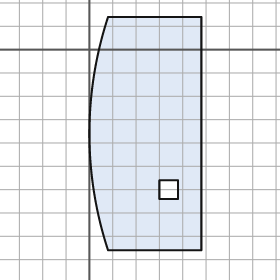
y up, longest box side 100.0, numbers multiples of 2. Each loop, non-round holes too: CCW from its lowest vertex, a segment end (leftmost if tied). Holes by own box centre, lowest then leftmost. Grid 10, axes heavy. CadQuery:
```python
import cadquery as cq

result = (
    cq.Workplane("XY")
    .moveTo(8.0, -86.0)
    .lineTo(48.0, -86.0)
    .lineTo(48.0, 14.0)
    .lineTo(8.0, 14.0)
    .threePointArc((0.0, -36.0), (8.0, -86.0))
    .close()
    .moveTo(30.0, -64.0)
    .lineTo(38.0, -64.0)
    .lineTo(38.0, -56.0)
    .lineTo(30.0, -56.0)
    .close()
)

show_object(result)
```